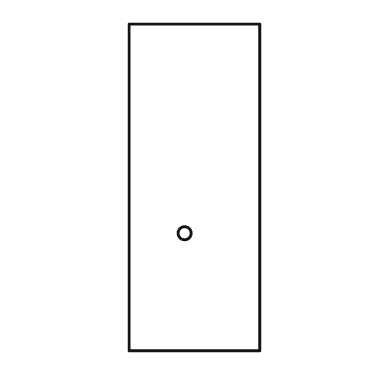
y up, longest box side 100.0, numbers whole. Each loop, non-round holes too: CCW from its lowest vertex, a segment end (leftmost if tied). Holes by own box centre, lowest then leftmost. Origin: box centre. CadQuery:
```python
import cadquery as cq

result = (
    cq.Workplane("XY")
    .moveTo(-20.0, -50.0)
    .lineTo(20.0, -50.0)
    .lineTo(20.0, 50.0)
    .lineTo(-20.0, 50.0)
    .close()
    .moveTo(-3.0, -14.0)
    .circle(2.0)
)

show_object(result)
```